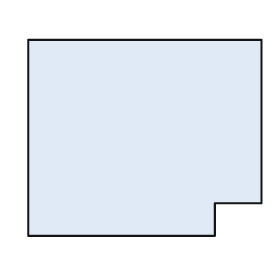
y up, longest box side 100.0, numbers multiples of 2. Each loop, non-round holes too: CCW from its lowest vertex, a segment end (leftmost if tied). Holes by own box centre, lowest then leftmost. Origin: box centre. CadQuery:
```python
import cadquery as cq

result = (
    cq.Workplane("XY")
    .moveTo(-50.0, -42.0)
    .lineTo(30.0, -42.0)
    .lineTo(30.0, -28.0)
    .lineTo(50.0, -28.0)
    .lineTo(50.0, 42.0)
    .lineTo(-50.0, 42.0)
    .close()
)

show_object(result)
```